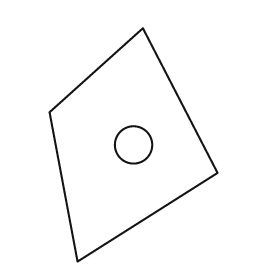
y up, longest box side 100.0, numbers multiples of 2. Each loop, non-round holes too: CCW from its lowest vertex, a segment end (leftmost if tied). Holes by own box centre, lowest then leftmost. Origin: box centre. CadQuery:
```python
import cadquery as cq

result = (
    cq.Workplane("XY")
    .moveTo(-24.0, -50.0)
    .lineTo(36.0, -12.0)
    .lineTo(4.0, 50.0)
    .lineTo(-36.0, 14.0)
    .close()
    .moveTo(0.0, 0.0)
    .circle(8.0)
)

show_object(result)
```